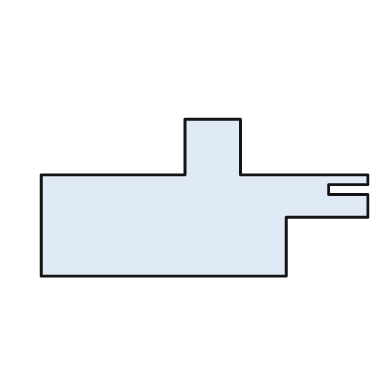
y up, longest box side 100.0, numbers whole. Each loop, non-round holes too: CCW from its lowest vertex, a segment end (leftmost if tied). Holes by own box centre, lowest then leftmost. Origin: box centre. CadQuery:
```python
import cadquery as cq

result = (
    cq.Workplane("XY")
    .moveTo(-50.0, -24.0)
    .lineTo(25.0, -24.0)
    .lineTo(25.0, -6.0)
    .lineTo(50.0, -6.0)
    .lineTo(50.0, 1.0)
    .lineTo(38.0, 1.0)
    .lineTo(38.0, 4.0)
    .lineTo(50.0, 4.0)
    .lineTo(50.0, 7.0)
    .lineTo(11.0, 7.0)
    .lineTo(11.0, 24.0)
    .lineTo(-6.0, 24.0)
    .lineTo(-6.0, 7.0)
    .lineTo(-50.0, 7.0)
    .close()
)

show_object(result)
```